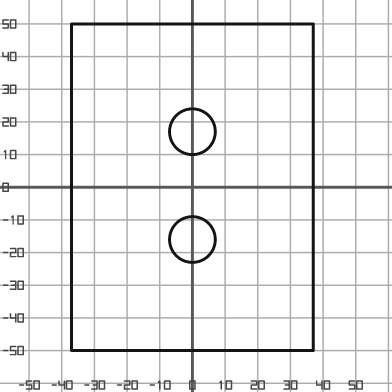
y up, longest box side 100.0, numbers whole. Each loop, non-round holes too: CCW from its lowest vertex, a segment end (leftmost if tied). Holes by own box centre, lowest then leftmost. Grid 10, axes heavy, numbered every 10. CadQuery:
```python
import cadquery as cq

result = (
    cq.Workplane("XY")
    .moveTo(-37.0, -50.0)
    .lineTo(37.0, -50.0)
    .lineTo(37.0, 50.0)
    .lineTo(-37.0, 50.0)
    .close()
    .moveTo(0.0, -16.0)
    .circle(7.0)
    .moveTo(0.0, 17.0)
    .circle(7.0)
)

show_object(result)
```